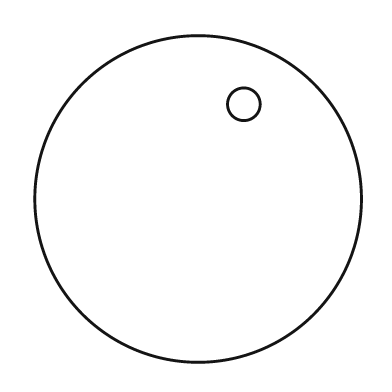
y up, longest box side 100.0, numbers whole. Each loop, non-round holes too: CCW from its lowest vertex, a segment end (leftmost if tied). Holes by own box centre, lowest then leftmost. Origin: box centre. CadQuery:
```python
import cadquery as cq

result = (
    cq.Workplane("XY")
    .moveTo(0.0, 0.0)
    .circle(50.0)
    .moveTo(14.0, 29.0)
    .circle(5.0)
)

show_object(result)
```